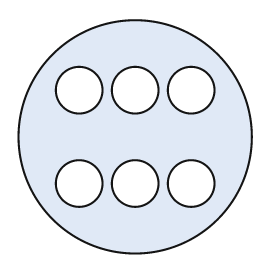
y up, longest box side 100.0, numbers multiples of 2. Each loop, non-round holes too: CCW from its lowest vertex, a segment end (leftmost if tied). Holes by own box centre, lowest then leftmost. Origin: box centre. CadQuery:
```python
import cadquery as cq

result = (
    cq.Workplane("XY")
    .moveTo(0.0, 0.0)
    .circle(50.0)
    .moveTo(-24.0, -20.0)
    .circle(10.0)
    .moveTo(0.0, -20.0)
    .circle(10.0)
    .moveTo(24.0, -20.0)
    .circle(10.0)
    .moveTo(-24.0, 20.0)
    .circle(10.0)
    .moveTo(0.0, 20.0)
    .circle(10.0)
    .moveTo(24.0, 20.0)
    .circle(10.0)
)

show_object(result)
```